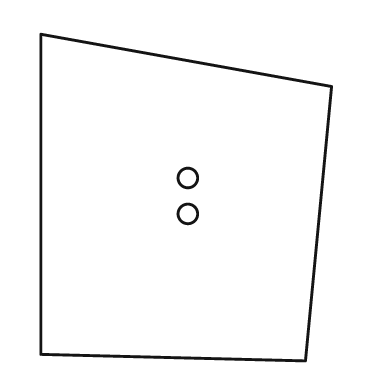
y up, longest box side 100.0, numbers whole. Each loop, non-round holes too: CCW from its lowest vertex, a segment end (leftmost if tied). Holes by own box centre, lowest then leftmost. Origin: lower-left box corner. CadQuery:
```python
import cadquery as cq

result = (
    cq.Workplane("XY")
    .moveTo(81.0, 0.0)
    .lineTo(89.0, 84.0)
    .lineTo(0.0, 100.0)
    .lineTo(0.0, 2.0)
    .close()
    .moveTo(45.0, 45.0)
    .circle(3.0)
    .moveTo(45.0, 56.0)
    .circle(3.0)
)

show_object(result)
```